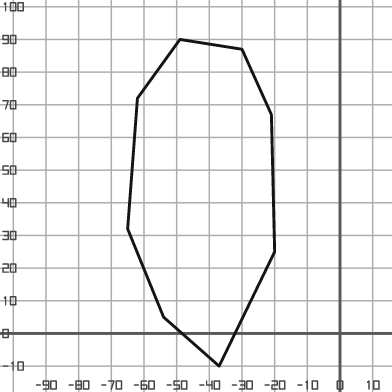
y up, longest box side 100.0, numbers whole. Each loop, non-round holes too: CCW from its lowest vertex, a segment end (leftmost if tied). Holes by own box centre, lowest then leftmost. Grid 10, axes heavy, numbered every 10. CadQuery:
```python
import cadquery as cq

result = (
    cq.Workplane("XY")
    .moveTo(-37.0, -10.0)
    .lineTo(-20.0, 25.0)
    .lineTo(-21.0, 67.0)
    .lineTo(-30.0, 87.0)
    .lineTo(-49.0, 90.0)
    .lineTo(-62.0, 72.0)
    .lineTo(-65.0, 32.0)
    .lineTo(-54.0, 5.0)
    .close()
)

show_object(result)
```